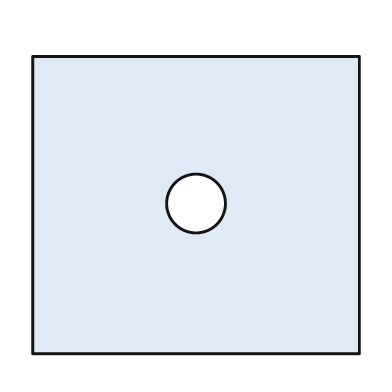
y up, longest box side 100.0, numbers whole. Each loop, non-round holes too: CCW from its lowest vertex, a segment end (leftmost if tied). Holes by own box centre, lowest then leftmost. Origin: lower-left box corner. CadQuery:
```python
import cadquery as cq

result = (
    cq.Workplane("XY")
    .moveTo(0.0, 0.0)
    .lineTo(100.0, 0.0)
    .lineTo(100.0, 91.0)
    .lineTo(0.0, 91.0)
    .close()
    .moveTo(50.0, 46.0)
    .circle(9.0)
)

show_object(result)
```